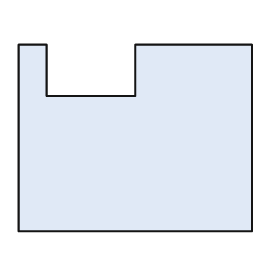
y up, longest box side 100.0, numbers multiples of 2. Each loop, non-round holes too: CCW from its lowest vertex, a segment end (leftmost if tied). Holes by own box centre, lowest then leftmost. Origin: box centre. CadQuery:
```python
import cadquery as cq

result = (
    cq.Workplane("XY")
    .moveTo(-50.0, -40.0)
    .lineTo(50.0, -40.0)
    .lineTo(50.0, 40.0)
    .lineTo(0.0, 40.0)
    .lineTo(0.0, 18.0)
    .lineTo(-38.0, 18.0)
    .lineTo(-38.0, 40.0)
    .lineTo(-50.0, 40.0)
    .close()
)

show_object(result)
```